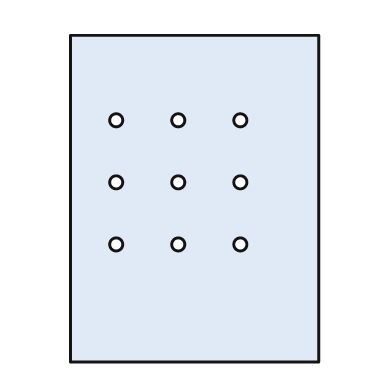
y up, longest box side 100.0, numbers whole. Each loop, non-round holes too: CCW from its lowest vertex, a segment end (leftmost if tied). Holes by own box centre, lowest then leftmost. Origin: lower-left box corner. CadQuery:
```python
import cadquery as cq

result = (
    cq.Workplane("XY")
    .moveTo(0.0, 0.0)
    .lineTo(76.0, 0.0)
    .lineTo(76.0, 100.0)
    .lineTo(0.0, 100.0)
    .close()
    .moveTo(14.0, 36.0)
    .circle(2.0)
    .moveTo(33.0, 36.0)
    .circle(2.0)
    .moveTo(52.0, 36.0)
    .circle(2.0)
    .moveTo(14.0, 55.0)
    .circle(2.0)
    .moveTo(33.0, 55.0)
    .circle(2.0)
    .moveTo(52.0, 55.0)
    .circle(2.0)
    .moveTo(14.0, 74.0)
    .circle(2.0)
    .moveTo(33.0, 74.0)
    .circle(2.0)
    .moveTo(52.0, 74.0)
    .circle(2.0)
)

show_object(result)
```